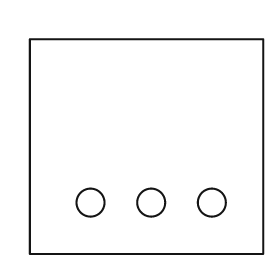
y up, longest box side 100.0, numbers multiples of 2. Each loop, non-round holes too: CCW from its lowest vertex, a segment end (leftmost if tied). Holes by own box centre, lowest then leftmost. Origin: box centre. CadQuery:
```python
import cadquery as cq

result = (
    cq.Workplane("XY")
    .moveTo(-50.0, -46.0)
    .lineTo(50.0, -46.0)
    .lineTo(50.0, 46.0)
    .lineTo(-50.0, 46.0)
    .close()
    .moveTo(-24.0, -24.0)
    .circle(6.0)
    .moveTo(2.0, -24.0)
    .circle(6.0)
    .moveTo(28.0, -24.0)
    .circle(6.0)
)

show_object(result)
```